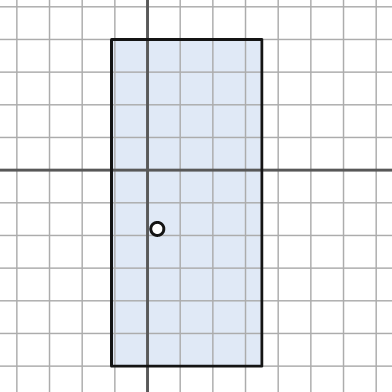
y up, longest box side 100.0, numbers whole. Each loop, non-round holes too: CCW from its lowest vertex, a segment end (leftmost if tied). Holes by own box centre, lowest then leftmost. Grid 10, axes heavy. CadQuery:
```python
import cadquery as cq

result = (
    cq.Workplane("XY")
    .moveTo(-11.0, -60.0)
    .lineTo(35.0, -60.0)
    .lineTo(35.0, 40.0)
    .lineTo(-11.0, 40.0)
    .close()
    .moveTo(3.0, -18.0)
    .circle(2.0)
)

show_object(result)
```